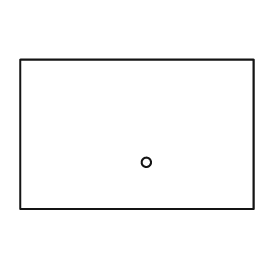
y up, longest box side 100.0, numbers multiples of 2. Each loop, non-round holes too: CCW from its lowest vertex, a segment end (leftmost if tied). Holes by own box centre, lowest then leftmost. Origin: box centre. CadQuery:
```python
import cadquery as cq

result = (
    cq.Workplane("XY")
    .moveTo(-50.0, -32.0)
    .lineTo(50.0, -32.0)
    .lineTo(50.0, 32.0)
    .lineTo(-50.0, 32.0)
    .close()
    .moveTo(4.0, -12.0)
    .circle(2.0)
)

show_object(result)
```